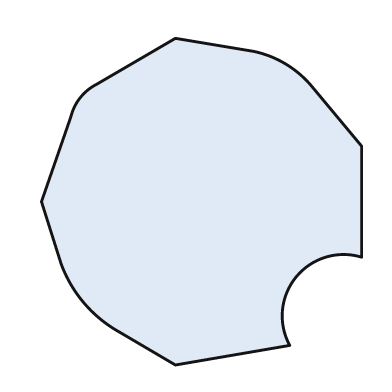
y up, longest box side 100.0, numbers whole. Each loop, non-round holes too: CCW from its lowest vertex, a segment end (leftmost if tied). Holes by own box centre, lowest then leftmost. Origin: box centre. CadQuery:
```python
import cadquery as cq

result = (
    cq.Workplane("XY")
    .moveTo(-8.0, -50.0)
    .lineTo(27.0, -44.0)
    .threePointArc((29.0, -23.0), (49.0, -17.0))
    .lineTo(49.0, 17.0)
    .lineTo(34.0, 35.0)
    .threePointArc((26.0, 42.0), (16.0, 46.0))
    .lineTo(-8.0, 50.0)
    .lineTo(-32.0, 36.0)
    .threePointArc((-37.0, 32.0), (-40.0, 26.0))
    .lineTo(-49.0, 0.0)
    .lineTo(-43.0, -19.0)
    .threePointArc((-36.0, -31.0), (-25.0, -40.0))
    .close()
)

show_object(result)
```